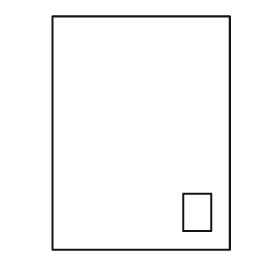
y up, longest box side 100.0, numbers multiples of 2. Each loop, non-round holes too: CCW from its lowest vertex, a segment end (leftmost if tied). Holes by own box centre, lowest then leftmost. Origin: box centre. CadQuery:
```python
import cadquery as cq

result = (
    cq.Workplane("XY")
    .moveTo(-38.0, -50.0)
    .lineTo(38.0, -50.0)
    .lineTo(38.0, 50.0)
    .lineTo(-38.0, 50.0)
    .close()
    .moveTo(18.0, -42.0)
    .lineTo(30.0, -42.0)
    .lineTo(30.0, -26.0)
    .lineTo(18.0, -26.0)
    .close()
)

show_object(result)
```